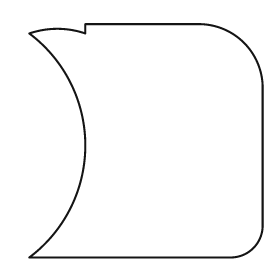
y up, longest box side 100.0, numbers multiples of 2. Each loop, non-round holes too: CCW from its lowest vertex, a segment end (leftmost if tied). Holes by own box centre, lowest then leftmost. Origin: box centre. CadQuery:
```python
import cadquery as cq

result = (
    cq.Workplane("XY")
    .moveTo(-50.0, -50.0)
    .lineTo(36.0, -50.0)
    .threePointArc((46.0, -46.0), (50.0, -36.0))
    .lineTo(50.0, 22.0)
    .threePointArc((42.0, 42.0), (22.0, 50.0))
    .lineTo(-26.0, 50.0)
    .lineTo(-26.0, 46.0)
    .threePointArc((-38.0, 48.0), (-50.0, 46.0))
    .threePointArc((-26.0, -2.0), (-50.0, -50.0))
    .close()
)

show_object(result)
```